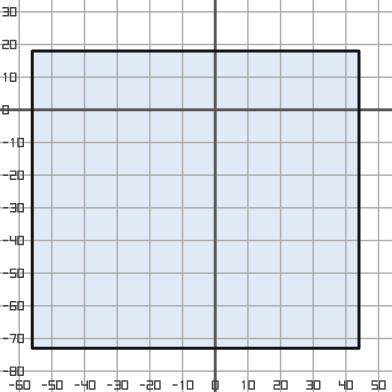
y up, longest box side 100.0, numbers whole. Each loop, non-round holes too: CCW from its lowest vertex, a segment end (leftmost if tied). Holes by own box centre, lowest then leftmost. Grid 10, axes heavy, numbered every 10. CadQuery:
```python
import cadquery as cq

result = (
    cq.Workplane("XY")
    .moveTo(-56.0, -73.0)
    .lineTo(44.0, -73.0)
    .lineTo(44.0, 18.0)
    .lineTo(-56.0, 18.0)
    .close()
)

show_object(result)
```